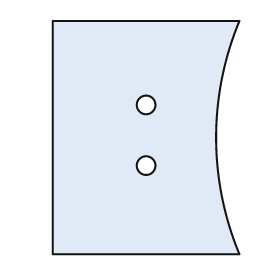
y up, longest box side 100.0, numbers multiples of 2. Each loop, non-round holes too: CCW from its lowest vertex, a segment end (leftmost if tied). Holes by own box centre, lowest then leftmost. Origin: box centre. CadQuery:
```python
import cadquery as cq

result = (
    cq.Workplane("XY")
    .moveTo(-40.0, -50.0)
    .lineTo(40.0, -50.0)
    .threePointArc((30.0, 0.0), (40.0, 50.0))
    .lineTo(-40.0, 50.0)
    .close()
    .moveTo(0.0, -12.0)
    .circle(4.0)
    .moveTo(0.0, 14.0)
    .circle(4.0)
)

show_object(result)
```